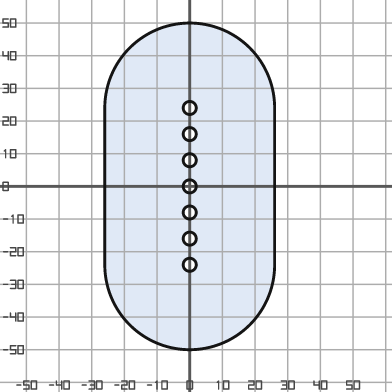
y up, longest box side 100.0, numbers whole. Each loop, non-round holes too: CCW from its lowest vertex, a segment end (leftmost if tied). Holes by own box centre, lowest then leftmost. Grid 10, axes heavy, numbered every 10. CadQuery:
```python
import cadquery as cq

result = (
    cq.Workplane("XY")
    .moveTo(-26.0, -24.0)
    .threePointArc((0.0, -50.0), (26.0, -24.0))
    .lineTo(26.0, 24.0)
    .threePointArc((0.0, 50.0), (-26.0, 24.0))
    .close()
    .moveTo(0.0, -24.0)
    .circle(2.0)
    .moveTo(0.0, -16.0)
    .circle(2.0)
    .moveTo(0.0, -8.0)
    .circle(2.0)
    .moveTo(0.0, 0.0)
    .circle(2.0)
    .moveTo(0.0, 8.0)
    .circle(2.0)
    .moveTo(0.0, 16.0)
    .circle(2.0)
    .moveTo(0.0, 24.0)
    .circle(2.0)
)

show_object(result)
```